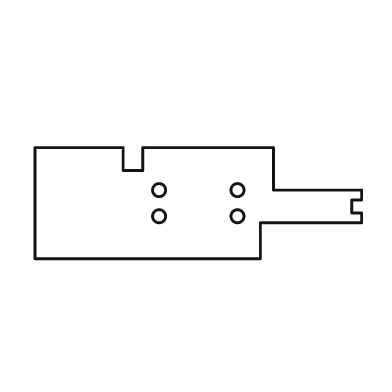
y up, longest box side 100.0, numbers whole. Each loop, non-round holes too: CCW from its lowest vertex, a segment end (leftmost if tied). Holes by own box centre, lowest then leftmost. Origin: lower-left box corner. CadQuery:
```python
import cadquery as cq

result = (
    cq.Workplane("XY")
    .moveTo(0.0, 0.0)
    .lineTo(69.0, 0.0)
    .lineTo(69.0, 11.0)
    .lineTo(100.0, 11.0)
    .lineTo(100.0, 14.0)
    .lineTo(97.0, 14.0)
    .lineTo(97.0, 18.0)
    .lineTo(100.0, 18.0)
    .lineTo(100.0, 21.0)
    .lineTo(73.0, 21.0)
    .lineTo(73.0, 34.0)
    .lineTo(33.0, 34.0)
    .lineTo(33.0, 27.0)
    .lineTo(27.0, 27.0)
    .lineTo(27.0, 34.0)
    .lineTo(0.0, 34.0)
    .close()
    .moveTo(38.0, 13.0)
    .circle(2.0)
    .moveTo(62.0, 13.0)
    .circle(2.0)
    .moveTo(38.0, 21.0)
    .circle(2.0)
    .moveTo(62.0, 21.0)
    .circle(2.0)
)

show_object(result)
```